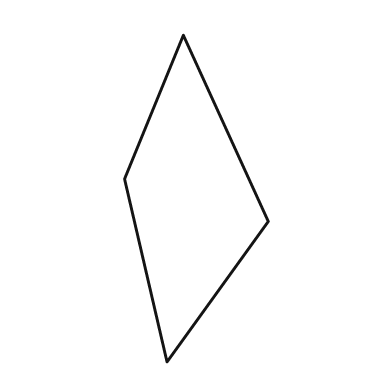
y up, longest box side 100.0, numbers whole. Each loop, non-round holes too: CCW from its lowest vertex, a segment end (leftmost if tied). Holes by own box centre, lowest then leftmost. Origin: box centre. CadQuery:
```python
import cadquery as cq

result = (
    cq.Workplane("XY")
    .moveTo(-9.0, -50.0)
    .lineTo(22.0, -7.0)
    .lineTo(-4.0, 50.0)
    .lineTo(-22.0, 6.0)
    .close()
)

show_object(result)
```